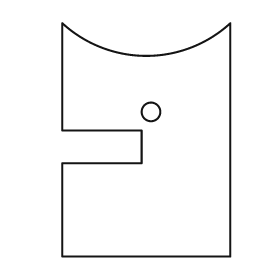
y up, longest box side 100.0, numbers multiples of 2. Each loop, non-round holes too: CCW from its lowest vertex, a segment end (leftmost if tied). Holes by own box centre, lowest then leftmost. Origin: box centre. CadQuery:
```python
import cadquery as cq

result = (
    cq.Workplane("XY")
    .moveTo(-36.0, -50.0)
    .lineTo(36.0, -50.0)
    .lineTo(36.0, 50.0)
    .threePointArc((0.0, 36.0), (-36.0, 50.0))
    .lineTo(-36.0, 4.0)
    .lineTo(-2.0, 4.0)
    .lineTo(-2.0, -10.0)
    .lineTo(-36.0, -10.0)
    .close()
    .moveTo(2.0, 12.0)
    .circle(4.0)
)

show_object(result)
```